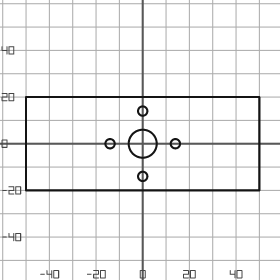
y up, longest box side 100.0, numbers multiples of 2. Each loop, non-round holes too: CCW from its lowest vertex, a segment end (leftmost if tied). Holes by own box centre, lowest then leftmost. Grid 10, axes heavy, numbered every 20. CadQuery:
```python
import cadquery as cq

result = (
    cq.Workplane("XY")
    .moveTo(-50.0, -20.0)
    .lineTo(50.0, -20.0)
    .lineTo(50.0, 20.0)
    .lineTo(-50.0, 20.0)
    .close()
    .moveTo(0.0, -14.0)
    .circle(2.0)
    .moveTo(-14.0, 0.0)
    .circle(2.0)
    .moveTo(0.0, 0.0)
    .circle(6.0)
    .moveTo(14.0, 0.0)
    .circle(2.0)
    .moveTo(0.0, 14.0)
    .circle(2.0)
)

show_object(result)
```